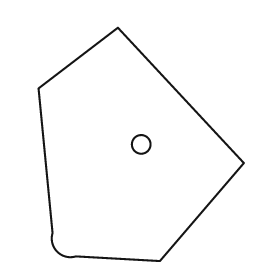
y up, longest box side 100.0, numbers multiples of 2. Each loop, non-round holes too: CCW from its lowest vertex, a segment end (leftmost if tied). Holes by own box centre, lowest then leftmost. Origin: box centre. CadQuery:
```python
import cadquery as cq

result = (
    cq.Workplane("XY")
    .moveTo(8.0, -50.0)
    .lineTo(44.0, -8.0)
    .lineTo(-10.0, 50.0)
    .lineTo(-44.0, 24.0)
    .lineTo(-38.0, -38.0)
    .threePointArc((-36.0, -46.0), (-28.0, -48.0))
    .close()
    .moveTo(0.0, 0.0)
    .circle(4.0)
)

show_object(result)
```